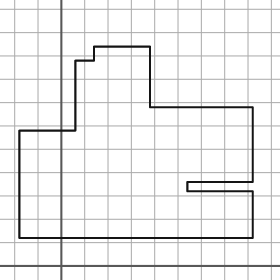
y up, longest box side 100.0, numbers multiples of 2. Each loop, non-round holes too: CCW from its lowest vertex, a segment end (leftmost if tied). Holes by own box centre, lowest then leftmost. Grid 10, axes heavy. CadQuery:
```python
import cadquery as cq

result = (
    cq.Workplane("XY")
    .moveTo(-18.0, 12.0)
    .lineTo(82.0, 12.0)
    .lineTo(82.0, 32.0)
    .lineTo(54.0, 32.0)
    .lineTo(54.0, 36.0)
    .lineTo(82.0, 36.0)
    .lineTo(82.0, 68.0)
    .lineTo(38.0, 68.0)
    .lineTo(38.0, 94.0)
    .lineTo(14.0, 94.0)
    .lineTo(14.0, 88.0)
    .lineTo(6.0, 88.0)
    .lineTo(6.0, 58.0)
    .lineTo(-18.0, 58.0)
    .close()
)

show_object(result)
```